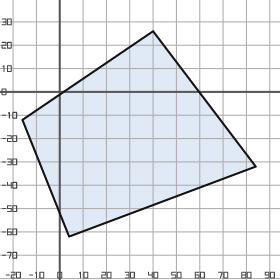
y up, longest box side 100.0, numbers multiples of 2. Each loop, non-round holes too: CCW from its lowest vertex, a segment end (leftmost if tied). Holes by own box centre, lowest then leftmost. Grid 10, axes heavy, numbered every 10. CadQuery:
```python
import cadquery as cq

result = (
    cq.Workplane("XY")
    .moveTo(4.0, -62.0)
    .lineTo(84.0, -32.0)
    .lineTo(40.0, 26.0)
    .lineTo(-16.0, -12.0)
    .close()
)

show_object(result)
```